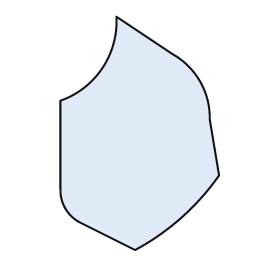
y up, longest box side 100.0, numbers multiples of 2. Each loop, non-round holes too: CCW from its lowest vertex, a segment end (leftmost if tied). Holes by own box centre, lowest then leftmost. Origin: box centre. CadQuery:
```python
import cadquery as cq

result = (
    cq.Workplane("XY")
    .moveTo(-2.0, -50.0)
    .threePointArc((18.0, -36.0), (34.0, -18.0))
    .lineTo(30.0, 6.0)
    .threePointArc((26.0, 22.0), (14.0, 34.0))
    .lineTo(-10.0, 50.0)
    .threePointArc((-16.0, 28.0), (-34.0, 14.0))
    .lineTo(-34.0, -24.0)
    .threePointArc((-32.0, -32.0), (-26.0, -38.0))
    .close()
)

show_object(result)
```